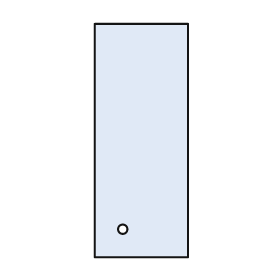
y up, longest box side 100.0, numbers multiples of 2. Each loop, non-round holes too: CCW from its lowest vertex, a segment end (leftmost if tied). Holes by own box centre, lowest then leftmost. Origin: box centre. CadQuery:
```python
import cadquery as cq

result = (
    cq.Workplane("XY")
    .moveTo(-20.0, -50.0)
    .lineTo(20.0, -50.0)
    .lineTo(20.0, 50.0)
    .lineTo(-20.0, 50.0)
    .close()
    .moveTo(-8.0, -38.0)
    .circle(2.0)
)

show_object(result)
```